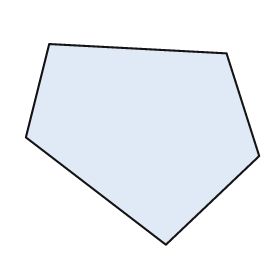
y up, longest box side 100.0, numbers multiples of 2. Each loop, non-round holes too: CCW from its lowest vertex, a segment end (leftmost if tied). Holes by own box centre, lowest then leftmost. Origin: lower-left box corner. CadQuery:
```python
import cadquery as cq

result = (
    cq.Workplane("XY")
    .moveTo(60.0, 0.0)
    .lineTo(100.0, 38.0)
    .lineTo(86.0, 82.0)
    .lineTo(10.0, 86.0)
    .lineTo(0.0, 46.0)
    .close()
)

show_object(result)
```